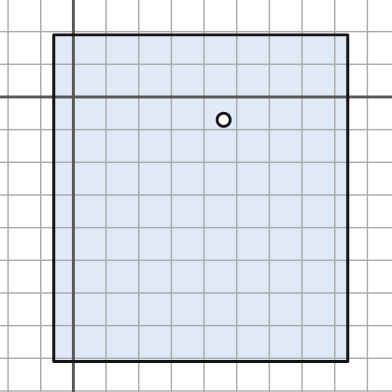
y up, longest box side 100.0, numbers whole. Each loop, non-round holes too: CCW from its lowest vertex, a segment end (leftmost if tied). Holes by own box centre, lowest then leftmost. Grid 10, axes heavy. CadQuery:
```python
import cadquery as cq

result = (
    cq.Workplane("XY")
    .moveTo(-6.0, -81.0)
    .lineTo(84.0, -81.0)
    .lineTo(84.0, 19.0)
    .lineTo(-6.0, 19.0)
    .close()
    .moveTo(46.0, -7.0)
    .circle(2.0)
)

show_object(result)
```